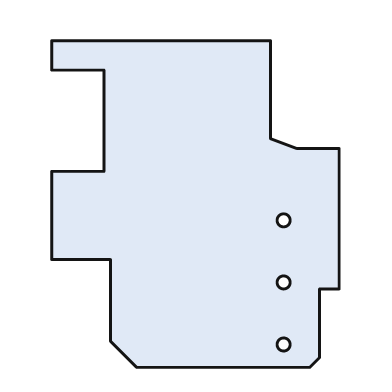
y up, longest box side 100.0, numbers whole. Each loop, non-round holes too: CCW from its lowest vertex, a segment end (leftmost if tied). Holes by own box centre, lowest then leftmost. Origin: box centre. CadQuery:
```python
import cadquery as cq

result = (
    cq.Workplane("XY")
    .moveTo(-18.0, -50.0)
    .lineTo(35.0, -50.0)
    .lineTo(38.0, -47.0)
    .lineTo(38.0, -26.0)
    .lineTo(44.0, -26.0)
    .lineTo(44.0, 17.0)
    .lineTo(31.0, 17.0)
    .lineTo(23.0, 20.0)
    .lineTo(23.0, 50.0)
    .lineTo(-44.0, 50.0)
    .lineTo(-44.0, 41.0)
    .lineTo(-28.0, 41.0)
    .lineTo(-28.0, 10.0)
    .lineTo(-44.0, 10.0)
    .lineTo(-44.0, -17.0)
    .lineTo(-26.0, -17.0)
    .lineTo(-26.0, -42.0)
    .close()
    .moveTo(27.0, -43.0)
    .circle(2.0)
    .moveTo(27.0, -24.0)
    .circle(2.0)
    .moveTo(27.0, -5.0)
    .circle(2.0)
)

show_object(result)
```